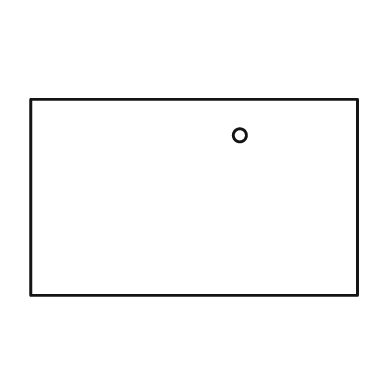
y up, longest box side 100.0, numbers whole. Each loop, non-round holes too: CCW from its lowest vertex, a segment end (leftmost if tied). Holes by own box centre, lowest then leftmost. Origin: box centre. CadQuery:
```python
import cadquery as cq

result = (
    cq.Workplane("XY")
    .moveTo(-50.0, -30.0)
    .lineTo(50.0, -30.0)
    .lineTo(50.0, 30.0)
    .lineTo(-50.0, 30.0)
    .close()
    .moveTo(14.0, 19.0)
    .circle(2.0)
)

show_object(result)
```